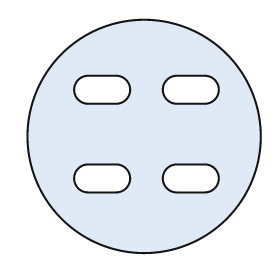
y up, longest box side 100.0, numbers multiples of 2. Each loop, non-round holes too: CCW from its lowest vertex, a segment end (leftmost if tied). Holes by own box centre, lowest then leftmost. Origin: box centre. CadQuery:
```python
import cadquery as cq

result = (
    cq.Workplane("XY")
    .moveTo(0.0, 0.0)
    .circle(50.0)
    .moveTo(-24.0, -24.0)
    .lineTo(-12.0, -24.0)
    .threePointArc((-6.0, -18.0), (-12.0, -12.0))
    .lineTo(-24.0, -12.0)
    .threePointArc((-30.0, -18.0), (-24.0, -24.0))
    .close()
    .moveTo(14.0, -24.0)
    .lineTo(26.0, -24.0)
    .threePointArc((32.0, -18.0), (26.0, -12.0))
    .lineTo(14.0, -12.0)
    .threePointArc((8.0, -18.0), (14.0, -24.0))
    .close()
    .moveTo(-24.0, 14.0)
    .lineTo(-12.0, 14.0)
    .threePointArc((-6.0, 20.0), (-12.0, 26.0))
    .lineTo(-24.0, 26.0)
    .threePointArc((-30.0, 20.0), (-24.0, 14.0))
    .close()
    .moveTo(14.0, 14.0)
    .lineTo(26.0, 14.0)
    .threePointArc((32.0, 20.0), (26.0, 26.0))
    .lineTo(14.0, 26.0)
    .threePointArc((8.0, 20.0), (14.0, 14.0))
    .close()
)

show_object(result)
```